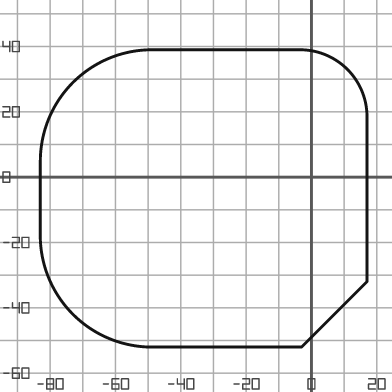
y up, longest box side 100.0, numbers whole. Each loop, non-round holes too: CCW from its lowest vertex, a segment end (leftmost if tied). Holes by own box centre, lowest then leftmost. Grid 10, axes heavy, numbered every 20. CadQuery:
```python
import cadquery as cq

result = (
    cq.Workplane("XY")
    .moveTo(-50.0, -52.0)
    .lineTo(-3.0, -52.0)
    .lineTo(17.0, -32.0)
    .lineTo(17.0, 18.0)
    .threePointArc((11.0, 33.0), (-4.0, 39.0))
    .lineTo(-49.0, 39.0)
    .threePointArc((-73.0, 29.0), (-83.0, 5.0))
    .lineTo(-83.0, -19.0)
    .threePointArc((-73.0, -42.0), (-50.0, -52.0))
    .close()
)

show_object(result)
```